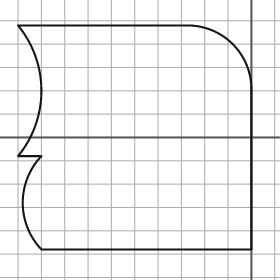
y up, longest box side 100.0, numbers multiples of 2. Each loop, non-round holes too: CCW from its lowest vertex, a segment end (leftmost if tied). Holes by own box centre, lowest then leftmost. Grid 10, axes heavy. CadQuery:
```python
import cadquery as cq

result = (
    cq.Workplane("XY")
    .moveTo(-90.0, -48.0)
    .lineTo(0.0, -48.0)
    .lineTo(0.0, 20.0)
    .threePointArc((-8.0, 40.0), (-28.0, 48.0))
    .lineTo(-100.0, 48.0)
    .threePointArc((-90.0, 20.0), (-100.0, -8.0))
    .lineTo(-90.0, -8.0)
    .threePointArc((-98.0, -28.0), (-90.0, -48.0))
    .close()
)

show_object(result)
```